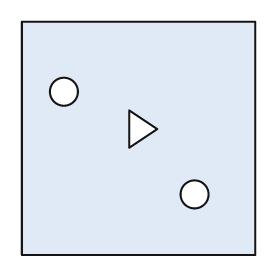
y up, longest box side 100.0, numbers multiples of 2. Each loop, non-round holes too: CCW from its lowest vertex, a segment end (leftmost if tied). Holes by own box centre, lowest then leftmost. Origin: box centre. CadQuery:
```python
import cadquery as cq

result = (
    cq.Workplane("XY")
    .moveTo(-50.0, -50.0)
    .lineTo(50.0, -50.0)
    .lineTo(50.0, 50.0)
    .lineTo(-50.0, 50.0)
    .close()
    .moveTo(24.0, -24.0)
    .circle(6.0)
    .moveTo(-4.0, -4.0)
    .lineTo(8.0, 4.0)
    .lineTo(-4.0, 12.0)
    .close()
    .moveTo(-32.0, 20.0)
    .circle(6.0)
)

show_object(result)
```